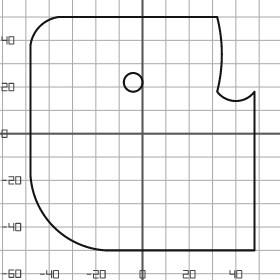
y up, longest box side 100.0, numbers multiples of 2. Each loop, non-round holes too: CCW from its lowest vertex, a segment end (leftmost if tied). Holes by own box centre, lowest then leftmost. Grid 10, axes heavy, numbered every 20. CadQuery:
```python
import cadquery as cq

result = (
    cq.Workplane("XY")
    .moveTo(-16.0, -50.0)
    .lineTo(48.0, -50.0)
    .lineTo(48.0, 18.0)
    .threePointArc((40.0, 14.0), (32.0, 18.0))
    .threePointArc((34.0, 34.0), (32.0, 50.0))
    .lineTo(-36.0, 50.0)
    .threePointArc((-44.0, 46.0), (-48.0, 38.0))
    .lineTo(-48.0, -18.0)
    .threePointArc((-38.0, -40.0), (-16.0, -50.0))
    .close()
    .moveTo(-4.0, 22.0)
    .circle(4.0)
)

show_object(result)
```